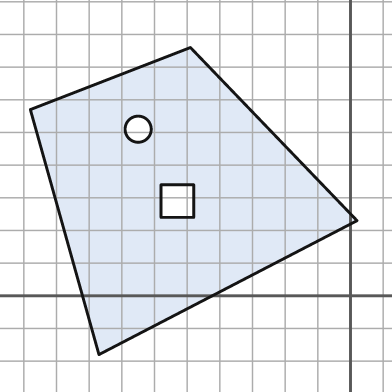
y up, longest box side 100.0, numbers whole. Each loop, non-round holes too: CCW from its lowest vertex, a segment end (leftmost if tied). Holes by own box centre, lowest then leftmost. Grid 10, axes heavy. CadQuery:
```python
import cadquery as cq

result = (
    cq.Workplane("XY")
    .moveTo(-77.0, -18.0)
    .lineTo(2.0, 23.0)
    .lineTo(-49.0, 76.0)
    .lineTo(-98.0, 57.0)
    .close()
    .moveTo(-58.0, 24.0)
    .lineTo(-48.0, 24.0)
    .lineTo(-48.0, 34.0)
    .lineTo(-58.0, 34.0)
    .close()
    .moveTo(-65.0, 51.0)
    .circle(4.0)
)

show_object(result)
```